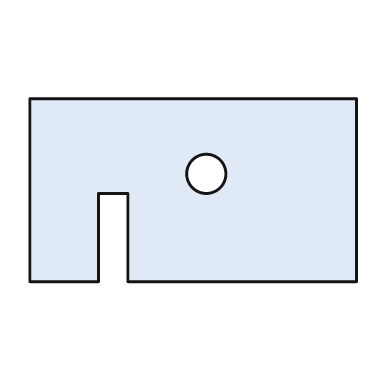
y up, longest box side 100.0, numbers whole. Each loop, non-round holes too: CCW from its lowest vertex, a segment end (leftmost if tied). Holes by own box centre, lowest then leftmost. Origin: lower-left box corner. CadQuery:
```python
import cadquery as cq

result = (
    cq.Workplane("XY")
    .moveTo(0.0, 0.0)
    .lineTo(21.0, 0.0)
    .lineTo(21.0, 27.0)
    .lineTo(30.0, 27.0)
    .lineTo(30.0, 0.0)
    .lineTo(100.0, 0.0)
    .lineTo(100.0, 56.0)
    .lineTo(0.0, 56.0)
    .close()
    .moveTo(54.0, 33.0)
    .circle(6.0)
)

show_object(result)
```